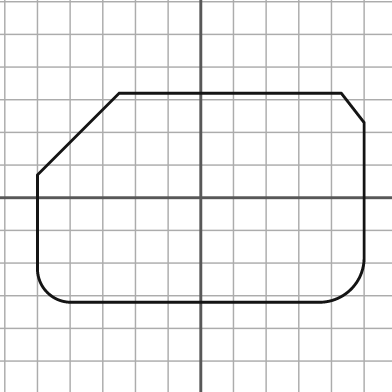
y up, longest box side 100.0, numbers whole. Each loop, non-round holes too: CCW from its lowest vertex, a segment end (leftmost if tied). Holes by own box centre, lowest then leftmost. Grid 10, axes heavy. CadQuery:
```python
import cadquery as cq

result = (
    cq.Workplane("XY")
    .moveTo(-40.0, -32.0)
    .lineTo(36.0, -32.0)
    .threePointArc((46.0, -28.0), (50.0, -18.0))
    .lineTo(50.0, 23.0)
    .lineTo(43.0, 32.0)
    .lineTo(-25.0, 32.0)
    .lineTo(-50.0, 7.0)
    .lineTo(-50.0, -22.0)
    .threePointArc((-47.0, -29.0), (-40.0, -32.0))
    .close()
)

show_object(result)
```